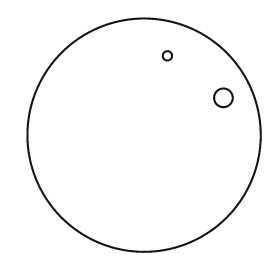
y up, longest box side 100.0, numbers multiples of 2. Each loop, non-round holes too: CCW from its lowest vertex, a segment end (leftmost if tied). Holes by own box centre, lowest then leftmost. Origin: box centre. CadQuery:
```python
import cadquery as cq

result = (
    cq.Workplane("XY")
    .moveTo(0.0, 0.0)
    .circle(50.0)
    .moveTo(34.0, 16.0)
    .circle(4.0)
    .moveTo(10.0, 34.0)
    .circle(2.0)
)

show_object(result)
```